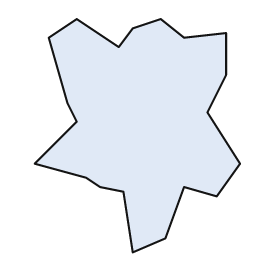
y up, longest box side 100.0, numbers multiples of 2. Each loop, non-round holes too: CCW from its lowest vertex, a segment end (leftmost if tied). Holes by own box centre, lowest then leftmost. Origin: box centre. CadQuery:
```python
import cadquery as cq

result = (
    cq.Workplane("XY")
    .moveTo(-2.0, -50.0)
    .lineTo(12.0, -44.0)
    .lineTo(20.0, -22.0)
    .lineTo(34.0, -26.0)
    .lineTo(44.0, -12.0)
    .lineTo(30.0, 10.0)
    .lineTo(38.0, 26.0)
    .lineTo(38.0, 44.0)
    .lineTo(20.0, 42.0)
    .lineTo(10.0, 50.0)
    .lineTo(-2.0, 46.0)
    .lineTo(-8.0, 38.0)
    .lineTo(-26.0, 50.0)
    .lineTo(-38.0, 42.0)
    .lineTo(-30.0, 14.0)
    .lineTo(-26.0, 6.0)
    .lineTo(-44.0, -12.0)
    .lineTo(-22.0, -18.0)
    .lineTo(-16.0, -22.0)
    .lineTo(-6.0, -24.0)
    .close()
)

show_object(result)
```